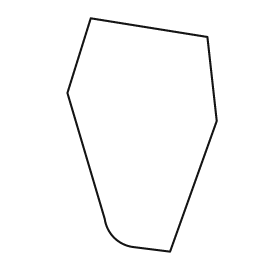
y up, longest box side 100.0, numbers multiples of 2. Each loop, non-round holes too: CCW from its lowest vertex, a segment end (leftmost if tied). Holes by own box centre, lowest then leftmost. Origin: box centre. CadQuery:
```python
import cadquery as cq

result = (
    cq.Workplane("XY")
    .moveTo(12.0, -50.0)
    .lineTo(32.0, 6.0)
    .lineTo(28.0, 42.0)
    .lineTo(-22.0, 50.0)
    .lineTo(-32.0, 18.0)
    .lineTo(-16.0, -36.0)
    .threePointArc((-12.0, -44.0), (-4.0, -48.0))
    .close()
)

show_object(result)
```